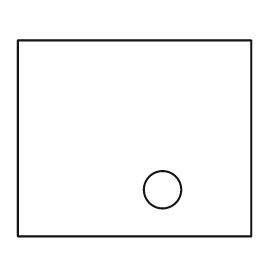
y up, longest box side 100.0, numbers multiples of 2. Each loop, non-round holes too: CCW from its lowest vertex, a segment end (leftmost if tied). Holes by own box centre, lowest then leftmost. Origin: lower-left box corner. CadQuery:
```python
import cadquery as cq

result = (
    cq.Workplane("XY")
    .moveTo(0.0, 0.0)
    .lineTo(100.0, 0.0)
    .lineTo(100.0, 84.0)
    .lineTo(0.0, 84.0)
    .close()
    .moveTo(62.0, 20.0)
    .circle(8.0)
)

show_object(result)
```